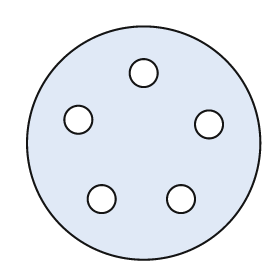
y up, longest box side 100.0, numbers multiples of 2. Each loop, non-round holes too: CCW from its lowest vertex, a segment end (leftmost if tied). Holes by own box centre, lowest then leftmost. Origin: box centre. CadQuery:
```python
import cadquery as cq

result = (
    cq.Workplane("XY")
    .moveTo(0.0, 0.0)
    .circle(50.0)
    .moveTo(-18.0, -24.0)
    .circle(6.0)
    .moveTo(16.0, -24.0)
    .circle(6.0)
    .moveTo(28.0, 8.0)
    .circle(6.0)
    .moveTo(-28.0, 10.0)
    .circle(6.0)
    .moveTo(0.0, 30.0)
    .circle(6.0)
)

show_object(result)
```